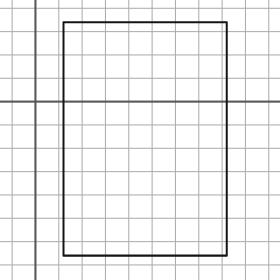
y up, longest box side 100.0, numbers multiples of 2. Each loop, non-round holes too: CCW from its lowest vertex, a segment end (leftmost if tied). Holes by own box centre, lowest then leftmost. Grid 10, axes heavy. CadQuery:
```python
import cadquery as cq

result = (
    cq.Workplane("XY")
    .moveTo(12.0, -66.0)
    .lineTo(82.0, -66.0)
    .lineTo(82.0, 34.0)
    .lineTo(12.0, 34.0)
    .close()
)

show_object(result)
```